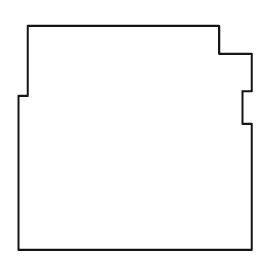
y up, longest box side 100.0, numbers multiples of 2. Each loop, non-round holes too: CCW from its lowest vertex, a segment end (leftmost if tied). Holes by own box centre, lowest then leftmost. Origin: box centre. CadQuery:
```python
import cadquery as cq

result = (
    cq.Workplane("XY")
    .moveTo(-50.0, -48.0)
    .lineTo(50.0, -48.0)
    .lineTo(50.0, 6.0)
    .lineTo(46.0, 6.0)
    .lineTo(46.0, 20.0)
    .lineTo(50.0, 20.0)
    .lineTo(50.0, 36.0)
    .lineTo(36.0, 36.0)
    .lineTo(36.0, 48.0)
    .lineTo(-46.0, 48.0)
    .lineTo(-46.0, 18.0)
    .lineTo(-50.0, 18.0)
    .close()
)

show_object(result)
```